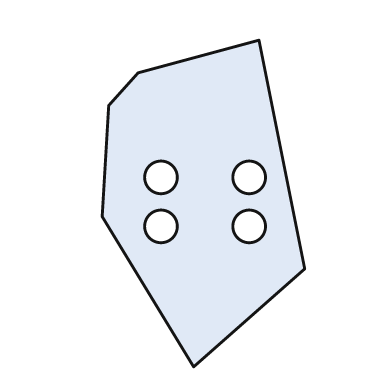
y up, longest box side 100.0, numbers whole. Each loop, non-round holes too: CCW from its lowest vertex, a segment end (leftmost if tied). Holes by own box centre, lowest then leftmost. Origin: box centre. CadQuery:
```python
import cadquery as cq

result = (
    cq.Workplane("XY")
    .moveTo(-3.0, -50.0)
    .lineTo(31.0, -20.0)
    .lineTo(17.0, 50.0)
    .lineTo(-20.0, 40.0)
    .lineTo(-29.0, 30.0)
    .lineTo(-31.0, -4.0)
    .close()
    .moveTo(-13.0, -7.0)
    .circle(5.0)
    .moveTo(14.0, -7.0)
    .circle(5.0)
    .moveTo(-13.0, 8.0)
    .circle(5.0)
    .moveTo(14.0, 8.0)
    .circle(5.0)
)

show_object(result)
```